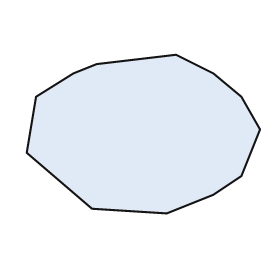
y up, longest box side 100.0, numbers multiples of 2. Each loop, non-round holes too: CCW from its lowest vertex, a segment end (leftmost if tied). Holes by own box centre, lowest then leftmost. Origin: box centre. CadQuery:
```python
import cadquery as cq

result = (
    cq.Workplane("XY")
    .moveTo(10.0, -34.0)
    .lineTo(30.0, -26.0)
    .lineTo(42.0, -18.0)
    .lineTo(50.0, 2.0)
    .lineTo(42.0, 16.0)
    .lineTo(30.0, 26.0)
    .lineTo(14.0, 34.0)
    .lineTo(-20.0, 30.0)
    .lineTo(-30.0, 26.0)
    .lineTo(-46.0, 16.0)
    .lineTo(-50.0, -8.0)
    .lineTo(-22.0, -32.0)
    .close()
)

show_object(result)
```